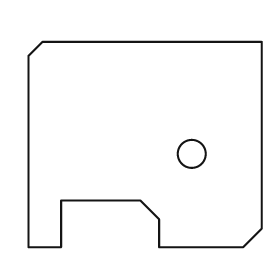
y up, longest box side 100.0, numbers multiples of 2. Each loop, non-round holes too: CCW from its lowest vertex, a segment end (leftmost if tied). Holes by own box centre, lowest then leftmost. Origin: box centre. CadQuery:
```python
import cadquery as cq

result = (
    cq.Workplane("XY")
    .moveTo(-50.0, -44.0)
    .lineTo(-36.0, -44.0)
    .lineTo(-36.0, -24.0)
    .lineTo(-2.0, -24.0)
    .lineTo(6.0, -32.0)
    .lineTo(6.0, -44.0)
    .lineTo(42.0, -44.0)
    .lineTo(50.0, -36.0)
    .lineTo(50.0, 44.0)
    .lineTo(-44.0, 44.0)
    .lineTo(-50.0, 38.0)
    .close()
    .moveTo(20.0, -4.0)
    .circle(6.0)
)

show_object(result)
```